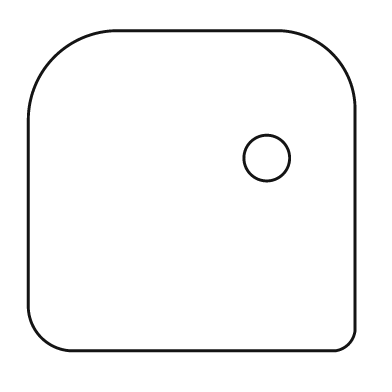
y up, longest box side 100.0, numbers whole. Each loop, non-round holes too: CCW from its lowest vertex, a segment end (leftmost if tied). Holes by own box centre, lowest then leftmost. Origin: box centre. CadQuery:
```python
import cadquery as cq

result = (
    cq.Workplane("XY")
    .moveTo(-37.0, -49.0)
    .lineTo(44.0, -49.0)
    .threePointArc((48.0, -47.0), (50.0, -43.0))
    .lineTo(50.0, 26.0)
    .threePointArc((43.0, 42.0), (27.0, 49.0))
    .lineTo(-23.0, 49.0)
    .threePointArc((-42.0, 41.0), (-50.0, 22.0))
    .lineTo(-50.0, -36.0)
    .threePointArc((-46.0, -45.0), (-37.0, -49.0))
    .close()
    .moveTo(23.0, 10.0)
    .circle(7.0)
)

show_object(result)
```